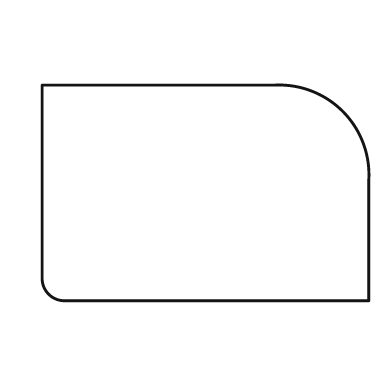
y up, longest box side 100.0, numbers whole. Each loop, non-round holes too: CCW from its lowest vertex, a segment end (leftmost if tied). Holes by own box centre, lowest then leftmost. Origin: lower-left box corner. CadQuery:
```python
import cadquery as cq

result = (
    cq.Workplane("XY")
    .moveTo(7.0, 0.0)
    .lineTo(100.0, 0.0)
    .lineTo(100.0, 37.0)
    .threePointArc((92.0, 58.0), (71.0, 66.0))
    .lineTo(0.0, 66.0)
    .lineTo(0.0, 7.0)
    .threePointArc((2.0, 2.0), (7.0, 0.0))
    .close()
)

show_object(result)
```